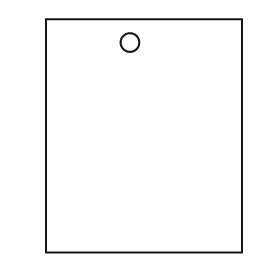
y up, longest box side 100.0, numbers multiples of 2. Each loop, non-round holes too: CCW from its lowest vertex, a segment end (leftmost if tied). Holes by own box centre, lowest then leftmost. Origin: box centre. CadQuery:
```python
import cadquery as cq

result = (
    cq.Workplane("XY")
    .moveTo(-42.0, -50.0)
    .lineTo(42.0, -50.0)
    .lineTo(42.0, 50.0)
    .lineTo(-42.0, 50.0)
    .close()
    .moveTo(-6.0, 40.0)
    .circle(4.0)
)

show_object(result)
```